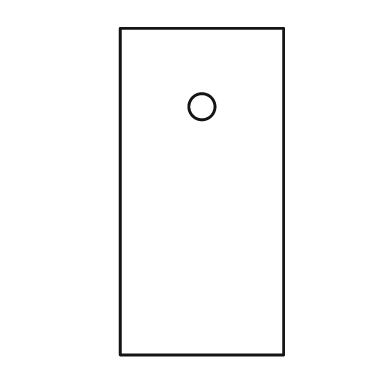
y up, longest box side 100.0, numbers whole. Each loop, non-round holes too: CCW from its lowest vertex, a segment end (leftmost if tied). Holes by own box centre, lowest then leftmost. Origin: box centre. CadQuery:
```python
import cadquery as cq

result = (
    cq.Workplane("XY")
    .moveTo(-25.0, -50.0)
    .lineTo(25.0, -50.0)
    .lineTo(25.0, 50.0)
    .lineTo(-25.0, 50.0)
    .close()
    .moveTo(0.0, 26.0)
    .circle(4.0)
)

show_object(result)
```